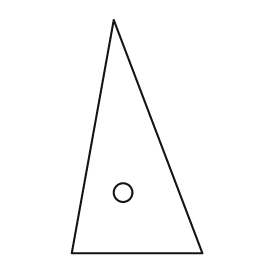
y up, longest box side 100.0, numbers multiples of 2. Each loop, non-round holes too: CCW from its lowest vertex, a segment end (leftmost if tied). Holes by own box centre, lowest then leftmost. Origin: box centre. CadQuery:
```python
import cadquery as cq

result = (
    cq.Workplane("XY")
    .moveTo(-28.0, -50.0)
    .lineTo(28.0, -50.0)
    .lineTo(-10.0, 50.0)
    .close()
    .moveTo(-6.0, -24.0)
    .circle(4.0)
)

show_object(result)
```